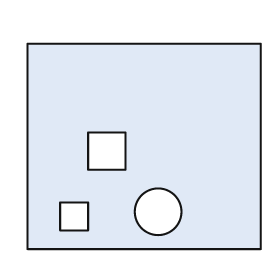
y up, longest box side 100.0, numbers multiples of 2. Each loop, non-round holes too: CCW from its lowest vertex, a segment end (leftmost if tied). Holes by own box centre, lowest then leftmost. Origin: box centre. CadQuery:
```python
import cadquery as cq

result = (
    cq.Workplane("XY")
    .moveTo(-50.0, -44.0)
    .lineTo(50.0, -44.0)
    .lineTo(50.0, 44.0)
    .lineTo(-50.0, 44.0)
    .close()
    .moveTo(-36.0, -36.0)
    .lineTo(-24.0, -36.0)
    .lineTo(-24.0, -24.0)
    .lineTo(-36.0, -24.0)
    .close()
    .moveTo(6.0, -28.0)
    .circle(10.0)
    .moveTo(-24.0, -10.0)
    .lineTo(-8.0, -10.0)
    .lineTo(-8.0, 6.0)
    .lineTo(-24.0, 6.0)
    .close()
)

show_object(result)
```